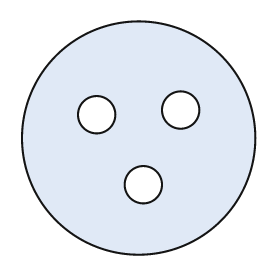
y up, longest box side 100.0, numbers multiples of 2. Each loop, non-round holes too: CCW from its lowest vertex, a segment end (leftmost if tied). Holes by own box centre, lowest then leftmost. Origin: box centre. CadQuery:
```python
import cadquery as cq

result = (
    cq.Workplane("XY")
    .moveTo(0.0, 0.0)
    .circle(50.0)
    .moveTo(2.0, -20.0)
    .circle(8.0)
    .moveTo(-18.0, 10.0)
    .circle(8.0)
    .moveTo(18.0, 12.0)
    .circle(8.0)
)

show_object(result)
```